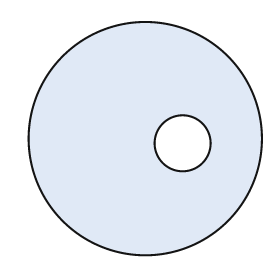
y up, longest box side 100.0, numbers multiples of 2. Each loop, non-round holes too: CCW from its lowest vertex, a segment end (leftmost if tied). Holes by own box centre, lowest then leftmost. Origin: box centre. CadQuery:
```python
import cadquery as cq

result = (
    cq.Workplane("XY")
    .moveTo(0.0, 0.0)
    .circle(50.0)
    .moveTo(16.0, -2.0)
    .circle(12.0)
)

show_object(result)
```